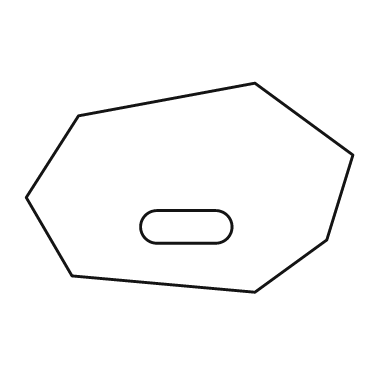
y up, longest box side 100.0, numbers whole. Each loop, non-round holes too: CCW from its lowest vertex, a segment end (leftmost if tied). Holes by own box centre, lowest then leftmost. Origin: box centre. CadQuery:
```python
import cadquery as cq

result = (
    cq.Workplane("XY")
    .moveTo(20.0, -32.0)
    .lineTo(42.0, -16.0)
    .lineTo(50.0, 10.0)
    .lineTo(20.0, 32.0)
    .lineTo(-34.0, 22.0)
    .lineTo(-50.0, -3.0)
    .lineTo(-36.0, -27.0)
    .close()
    .moveTo(-10.0, -17.0)
    .lineTo(8.0, -17.0)
    .threePointArc((13.0, -12.0), (8.0, -7.0))
    .lineTo(-10.0, -7.0)
    .threePointArc((-15.0, -12.0), (-10.0, -17.0))
    .close()
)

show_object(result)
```